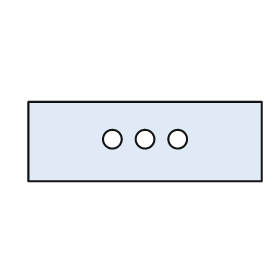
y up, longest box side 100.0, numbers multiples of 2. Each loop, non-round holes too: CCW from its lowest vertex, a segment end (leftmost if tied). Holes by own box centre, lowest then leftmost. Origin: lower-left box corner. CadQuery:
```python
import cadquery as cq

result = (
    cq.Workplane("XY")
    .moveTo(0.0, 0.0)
    .lineTo(100.0, 0.0)
    .lineTo(100.0, 34.0)
    .lineTo(0.0, 34.0)
    .close()
    .moveTo(36.0, 18.0)
    .circle(4.0)
    .moveTo(50.0, 18.0)
    .circle(4.0)
    .moveTo(64.0, 18.0)
    .circle(4.0)
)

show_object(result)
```